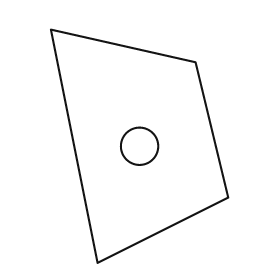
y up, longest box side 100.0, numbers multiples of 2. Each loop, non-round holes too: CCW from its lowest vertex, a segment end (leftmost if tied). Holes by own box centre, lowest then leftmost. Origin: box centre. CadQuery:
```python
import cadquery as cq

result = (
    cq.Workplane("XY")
    .moveTo(-18.0, -50.0)
    .lineTo(38.0, -22.0)
    .lineTo(24.0, 36.0)
    .lineTo(-38.0, 50.0)
    .close()
    .moveTo(0.0, 0.0)
    .circle(8.0)
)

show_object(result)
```